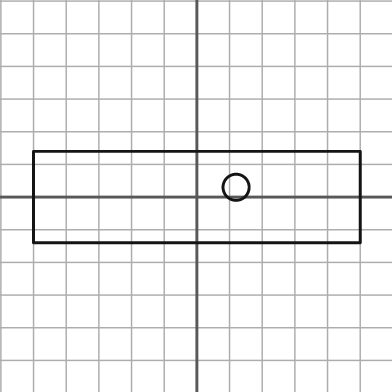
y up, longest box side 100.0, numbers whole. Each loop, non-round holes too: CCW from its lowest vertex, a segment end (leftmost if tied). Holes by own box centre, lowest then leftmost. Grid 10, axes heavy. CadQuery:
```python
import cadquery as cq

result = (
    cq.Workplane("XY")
    .moveTo(-50.0, -14.0)
    .lineTo(50.0, -14.0)
    .lineTo(50.0, 14.0)
    .lineTo(-50.0, 14.0)
    .close()
    .moveTo(12.0, 3.0)
    .circle(4.0)
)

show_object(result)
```